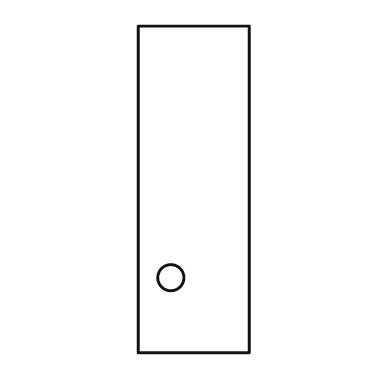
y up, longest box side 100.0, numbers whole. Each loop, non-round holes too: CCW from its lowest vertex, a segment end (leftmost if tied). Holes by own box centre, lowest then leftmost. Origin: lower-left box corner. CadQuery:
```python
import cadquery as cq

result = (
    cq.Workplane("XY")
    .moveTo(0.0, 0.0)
    .lineTo(34.0, 0.0)
    .lineTo(34.0, 100.0)
    .lineTo(0.0, 100.0)
    .close()
    .moveTo(10.0, 23.0)
    .circle(4.0)
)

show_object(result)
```